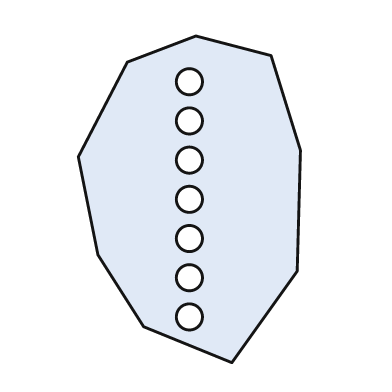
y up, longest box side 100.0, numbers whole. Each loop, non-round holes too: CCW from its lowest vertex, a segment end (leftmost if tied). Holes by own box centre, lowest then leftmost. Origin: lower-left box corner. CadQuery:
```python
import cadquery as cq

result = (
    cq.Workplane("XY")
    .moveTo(47.0, 0.0)
    .lineTo(67.0, 28.0)
    .lineTo(68.0, 65.0)
    .lineTo(59.0, 94.0)
    .lineTo(36.0, 100.0)
    .lineTo(15.0, 92.0)
    .lineTo(0.0, 63.0)
    .lineTo(6.0, 33.0)
    .lineTo(20.0, 11.0)
    .close()
    .moveTo(34.0, 14.0)
    .circle(4.0)
    .moveTo(34.0, 26.0)
    .circle(4.0)
    .moveTo(34.0, 38.0)
    .circle(4.0)
    .moveTo(34.0, 50.0)
    .circle(4.0)
    .moveTo(34.0, 62.0)
    .circle(4.0)
    .moveTo(34.0, 74.0)
    .circle(4.0)
    .moveTo(34.0, 86.0)
    .circle(4.0)
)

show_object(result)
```